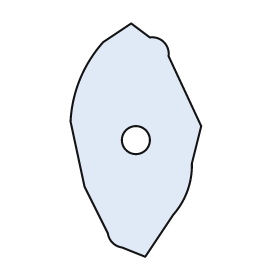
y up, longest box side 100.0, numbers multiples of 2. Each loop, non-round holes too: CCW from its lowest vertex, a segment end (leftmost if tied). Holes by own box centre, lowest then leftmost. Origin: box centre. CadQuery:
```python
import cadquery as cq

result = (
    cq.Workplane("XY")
    .moveTo(4.0, -50.0)
    .lineTo(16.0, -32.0)
    .threePointArc((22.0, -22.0), (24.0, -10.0))
    .lineTo(28.0, 6.0)
    .lineTo(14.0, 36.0)
    .threePointArc((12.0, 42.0), (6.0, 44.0))
    .lineTo(-2.0, 50.0)
    .lineTo(-14.0, 42.0)
    .threePointArc((-24.0, 26.0), (-28.0, 8.0))
    .lineTo(-22.0, -20.0)
    .lineTo(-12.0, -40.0)
    .threePointArc((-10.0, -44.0), (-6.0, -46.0))
    .close()
    .moveTo(0.0, 0.0)
    .circle(6.0)
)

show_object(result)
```